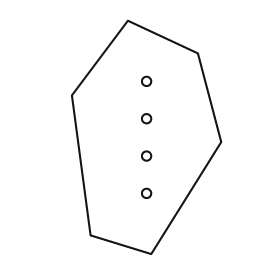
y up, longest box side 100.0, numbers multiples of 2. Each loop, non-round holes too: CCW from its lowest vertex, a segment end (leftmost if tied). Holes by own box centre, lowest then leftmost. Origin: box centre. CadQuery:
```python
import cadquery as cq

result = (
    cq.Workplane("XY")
    .moveTo(2.0, -50.0)
    .lineTo(32.0, -2.0)
    .lineTo(22.0, 36.0)
    .lineTo(-8.0, 50.0)
    .lineTo(-32.0, 18.0)
    .lineTo(-24.0, -42.0)
    .close()
    .moveTo(0.0, -24.0)
    .circle(2.0)
    .moveTo(0.0, -8.0)
    .circle(2.0)
    .moveTo(0.0, 8.0)
    .circle(2.0)
    .moveTo(0.0, 24.0)
    .circle(2.0)
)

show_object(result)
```